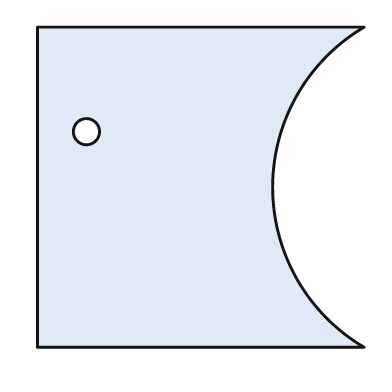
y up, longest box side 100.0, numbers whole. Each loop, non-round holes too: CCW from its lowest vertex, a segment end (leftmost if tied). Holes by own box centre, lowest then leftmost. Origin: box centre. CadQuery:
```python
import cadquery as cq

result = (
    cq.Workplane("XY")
    .moveTo(-50.0, -49.0)
    .lineTo(50.0, -49.0)
    .threePointArc((22.0, 0.0), (50.0, 49.0))
    .lineTo(-50.0, 49.0)
    .close()
    .moveTo(-35.0, 17.0)
    .circle(4.0)
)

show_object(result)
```